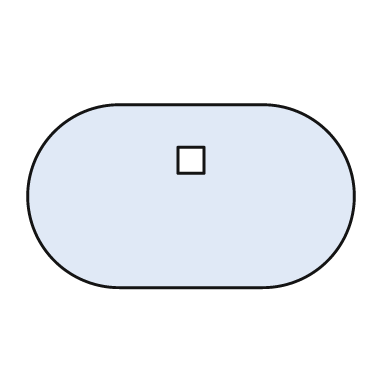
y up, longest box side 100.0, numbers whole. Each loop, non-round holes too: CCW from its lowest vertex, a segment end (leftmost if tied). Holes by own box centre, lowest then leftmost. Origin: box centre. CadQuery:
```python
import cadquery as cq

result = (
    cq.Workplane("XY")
    .moveTo(-22.0, -28.0)
    .lineTo(22.0, -28.0)
    .threePointArc((50.0, 0.0), (22.0, 28.0))
    .lineTo(-22.0, 28.0)
    .threePointArc((-50.0, 0.0), (-22.0, -28.0))
    .close()
    .moveTo(-4.0, 7.0)
    .lineTo(4.0, 7.0)
    .lineTo(4.0, 15.0)
    .lineTo(-4.0, 15.0)
    .close()
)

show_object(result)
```